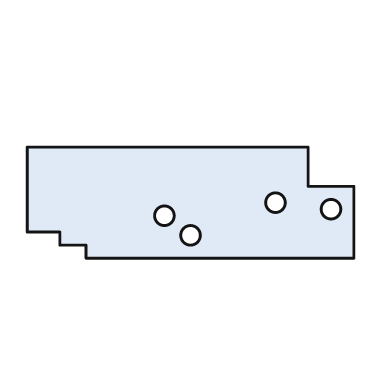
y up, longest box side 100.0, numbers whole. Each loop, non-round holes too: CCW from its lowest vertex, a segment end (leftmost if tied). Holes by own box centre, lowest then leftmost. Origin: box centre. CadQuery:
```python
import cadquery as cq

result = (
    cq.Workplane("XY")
    .moveTo(-32.0, -17.0)
    .lineTo(50.0, -17.0)
    .lineTo(50.0, 5.0)
    .lineTo(36.0, 5.0)
    .lineTo(36.0, 17.0)
    .lineTo(-50.0, 17.0)
    .lineTo(-50.0, -9.0)
    .lineTo(-40.0, -9.0)
    .lineTo(-40.0, -13.0)
    .lineTo(-32.0, -13.0)
    .close()
    .moveTo(0.0, -10.0)
    .circle(3.0)
    .moveTo(-8.0, -4.0)
    .circle(3.0)
    .moveTo(43.0, -2.0)
    .circle(3.0)
    .moveTo(26.0, 0.0)
    .circle(3.0)
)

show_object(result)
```